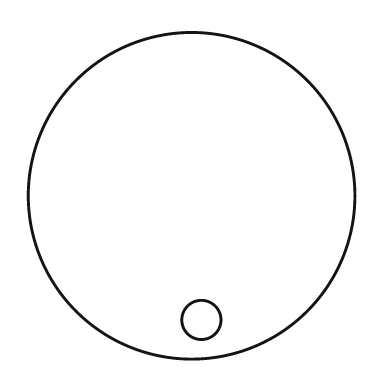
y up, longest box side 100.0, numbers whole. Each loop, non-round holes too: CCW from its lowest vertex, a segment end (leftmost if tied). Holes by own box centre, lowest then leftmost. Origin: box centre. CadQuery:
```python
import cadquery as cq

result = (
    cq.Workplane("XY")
    .moveTo(0.0, 0.0)
    .circle(50.0)
    .moveTo(3.0, -38.0)
    .circle(6.0)
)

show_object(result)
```